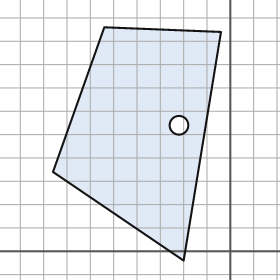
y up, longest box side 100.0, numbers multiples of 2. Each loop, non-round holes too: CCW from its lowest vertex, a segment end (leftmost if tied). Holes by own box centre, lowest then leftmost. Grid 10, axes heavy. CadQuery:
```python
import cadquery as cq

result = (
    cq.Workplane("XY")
    .moveTo(-20.0, -4.0)
    .lineTo(-4.0, 94.0)
    .lineTo(-54.0, 96.0)
    .lineTo(-76.0, 34.0)
    .close()
    .moveTo(-22.0, 54.0)
    .circle(4.0)
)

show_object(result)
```